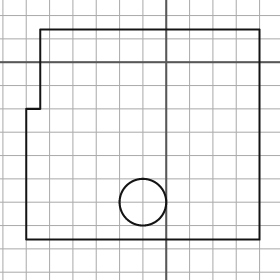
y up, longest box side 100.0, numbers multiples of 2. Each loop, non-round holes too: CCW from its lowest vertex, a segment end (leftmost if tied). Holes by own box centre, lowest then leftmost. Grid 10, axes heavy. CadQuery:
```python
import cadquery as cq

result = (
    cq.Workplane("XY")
    .moveTo(-60.0, -76.0)
    .lineTo(40.0, -76.0)
    .lineTo(40.0, 14.0)
    .lineTo(-54.0, 14.0)
    .lineTo(-54.0, -20.0)
    .lineTo(-60.0, -20.0)
    .close()
    .moveTo(-10.0, -60.0)
    .circle(10.0)
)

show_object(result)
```